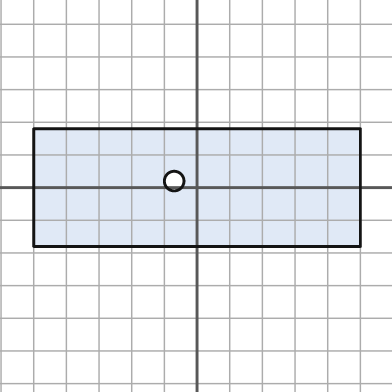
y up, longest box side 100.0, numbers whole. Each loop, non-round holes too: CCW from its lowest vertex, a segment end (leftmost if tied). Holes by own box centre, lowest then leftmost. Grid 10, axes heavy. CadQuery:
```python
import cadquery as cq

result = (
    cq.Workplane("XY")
    .moveTo(-50.0, -18.0)
    .lineTo(50.0, -18.0)
    .lineTo(50.0, 18.0)
    .lineTo(-50.0, 18.0)
    .close()
    .moveTo(-7.0, 2.0)
    .circle(3.0)
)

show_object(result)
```